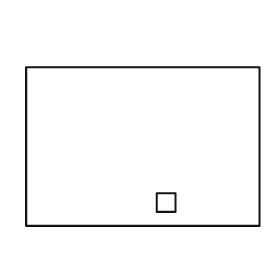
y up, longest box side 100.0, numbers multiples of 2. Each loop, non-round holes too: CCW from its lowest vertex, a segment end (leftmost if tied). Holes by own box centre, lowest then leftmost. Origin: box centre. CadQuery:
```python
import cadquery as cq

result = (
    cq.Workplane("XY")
    .moveTo(-50.0, -34.0)
    .lineTo(50.0, -34.0)
    .lineTo(50.0, 34.0)
    .lineTo(-50.0, 34.0)
    .close()
    .moveTo(6.0, -28.0)
    .lineTo(14.0, -28.0)
    .lineTo(14.0, -20.0)
    .lineTo(6.0, -20.0)
    .close()
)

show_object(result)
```